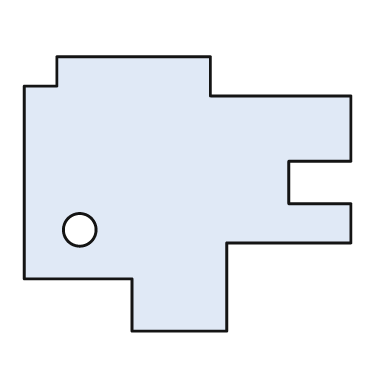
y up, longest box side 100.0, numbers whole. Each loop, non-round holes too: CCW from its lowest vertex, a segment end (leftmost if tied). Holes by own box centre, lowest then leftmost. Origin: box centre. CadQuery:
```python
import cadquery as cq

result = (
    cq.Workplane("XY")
    .moveTo(-17.0, -42.0)
    .lineTo(12.0, -42.0)
    .lineTo(12.0, -15.0)
    .lineTo(50.0, -15.0)
    .lineTo(50.0, -3.0)
    .lineTo(31.0, -3.0)
    .lineTo(31.0, 10.0)
    .lineTo(50.0, 10.0)
    .lineTo(50.0, 30.0)
    .lineTo(7.0, 30.0)
    .lineTo(7.0, 42.0)
    .lineTo(-40.0, 42.0)
    .lineTo(-40.0, 33.0)
    .lineTo(-50.0, 33.0)
    .lineTo(-50.0, -26.0)
    .lineTo(-17.0, -26.0)
    .close()
    .moveTo(-33.0, -11.0)
    .circle(5.0)
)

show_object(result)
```